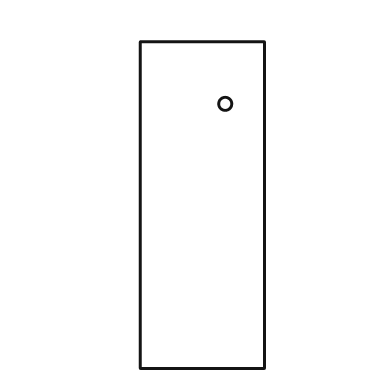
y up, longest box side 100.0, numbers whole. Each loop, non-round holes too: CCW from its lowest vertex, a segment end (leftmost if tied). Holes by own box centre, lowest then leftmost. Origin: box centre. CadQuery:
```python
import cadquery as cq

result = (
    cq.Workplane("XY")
    .moveTo(-19.0, -50.0)
    .lineTo(19.0, -50.0)
    .lineTo(19.0, 50.0)
    .lineTo(-19.0, 50.0)
    .close()
    .moveTo(7.0, 31.0)
    .circle(2.0)
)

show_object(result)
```